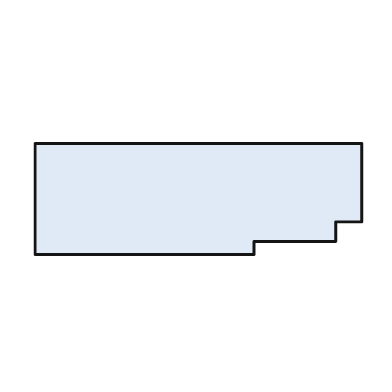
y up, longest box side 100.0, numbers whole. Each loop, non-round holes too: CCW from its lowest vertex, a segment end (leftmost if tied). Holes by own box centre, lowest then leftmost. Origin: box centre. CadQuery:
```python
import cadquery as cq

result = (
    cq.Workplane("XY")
    .moveTo(-50.0, -17.0)
    .lineTo(17.0, -17.0)
    .lineTo(17.0, -13.0)
    .lineTo(42.0, -13.0)
    .lineTo(42.0, -7.0)
    .lineTo(50.0, -7.0)
    .lineTo(50.0, 17.0)
    .lineTo(-50.0, 17.0)
    .close()
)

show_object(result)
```